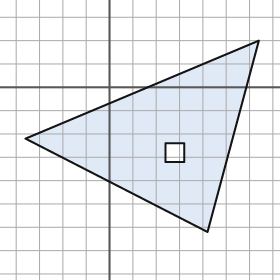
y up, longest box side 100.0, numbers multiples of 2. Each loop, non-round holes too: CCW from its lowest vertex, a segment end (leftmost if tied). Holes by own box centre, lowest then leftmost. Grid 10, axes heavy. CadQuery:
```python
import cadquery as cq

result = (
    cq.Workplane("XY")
    .moveTo(42.0, -62.0)
    .lineTo(64.0, 20.0)
    .lineTo(-36.0, -22.0)
    .close()
    .moveTo(24.0, -32.0)
    .lineTo(32.0, -32.0)
    .lineTo(32.0, -24.0)
    .lineTo(24.0, -24.0)
    .close()
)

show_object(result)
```